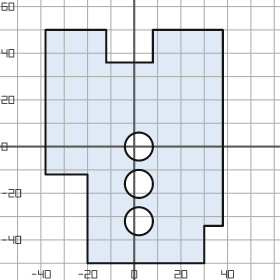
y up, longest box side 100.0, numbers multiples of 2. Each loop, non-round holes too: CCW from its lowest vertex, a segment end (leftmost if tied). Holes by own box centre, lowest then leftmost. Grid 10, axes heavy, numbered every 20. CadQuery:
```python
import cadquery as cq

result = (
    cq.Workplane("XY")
    .moveTo(-20.0, -50.0)
    .lineTo(30.0, -50.0)
    .lineTo(30.0, -34.0)
    .lineTo(38.0, -34.0)
    .lineTo(38.0, 50.0)
    .lineTo(8.0, 50.0)
    .lineTo(8.0, 36.0)
    .lineTo(-12.0, 36.0)
    .lineTo(-12.0, 50.0)
    .lineTo(-38.0, 50.0)
    .lineTo(-38.0, -12.0)
    .lineTo(-20.0, -12.0)
    .close()
    .moveTo(2.0, -32.0)
    .circle(6.0)
    .moveTo(2.0, -16.0)
    .circle(6.0)
    .moveTo(2.0, 0.0)
    .circle(6.0)
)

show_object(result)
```